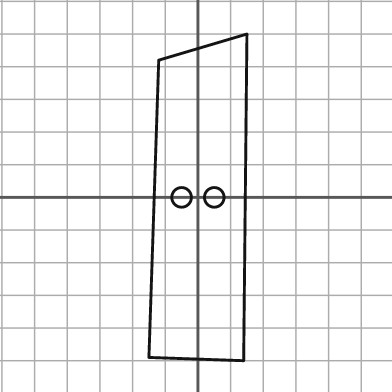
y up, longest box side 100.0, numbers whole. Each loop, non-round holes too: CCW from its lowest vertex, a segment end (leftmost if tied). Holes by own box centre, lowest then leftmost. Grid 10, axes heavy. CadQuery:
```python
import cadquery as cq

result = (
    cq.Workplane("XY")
    .moveTo(14.0, -50.0)
    .lineTo(15.0, 50.0)
    .lineTo(-12.0, 42.0)
    .lineTo(-15.0, -49.0)
    .close()
    .moveTo(-5.0, 0.0)
    .circle(3.0)
    .moveTo(5.0, 0.0)
    .circle(3.0)
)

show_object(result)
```